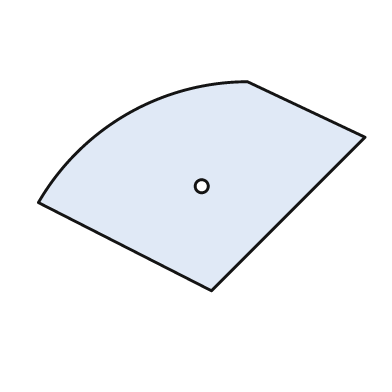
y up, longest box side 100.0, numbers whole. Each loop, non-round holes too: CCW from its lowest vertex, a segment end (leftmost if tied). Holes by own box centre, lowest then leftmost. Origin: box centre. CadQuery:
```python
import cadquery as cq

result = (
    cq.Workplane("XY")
    .moveTo(3.0, -32.0)
    .lineTo(50.0, 15.0)
    .lineTo(14.0, 32.0)
    .threePointArc((-23.0, 22.0), (-50.0, -5.0))
    .close()
    .moveTo(0.0, 0.0)
    .circle(2.0)
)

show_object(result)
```